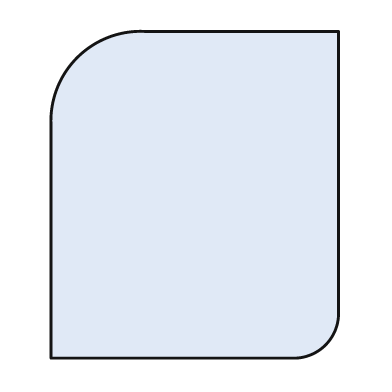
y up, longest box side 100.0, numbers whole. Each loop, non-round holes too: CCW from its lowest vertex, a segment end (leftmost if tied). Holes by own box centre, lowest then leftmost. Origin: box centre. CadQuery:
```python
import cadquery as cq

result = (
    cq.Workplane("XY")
    .moveTo(-44.0, -50.0)
    .lineTo(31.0, -50.0)
    .threePointArc((40.0, -46.0), (44.0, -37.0))
    .lineTo(44.0, 50.0)
    .lineTo(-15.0, 50.0)
    .threePointArc((-36.0, 42.0), (-44.0, 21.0))
    .close()
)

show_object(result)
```